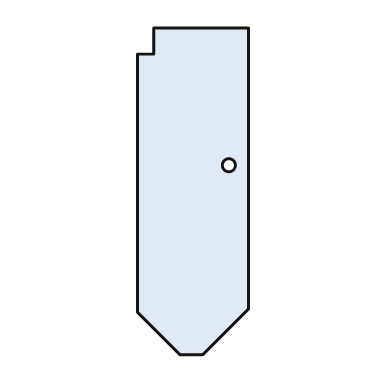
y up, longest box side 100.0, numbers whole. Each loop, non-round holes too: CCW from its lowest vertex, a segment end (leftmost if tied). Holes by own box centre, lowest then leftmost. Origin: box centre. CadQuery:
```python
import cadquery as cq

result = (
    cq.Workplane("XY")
    .moveTo(-4.0, -50.0)
    .lineTo(3.0, -50.0)
    .lineTo(17.0, -36.0)
    .lineTo(17.0, 50.0)
    .lineTo(-12.0, 50.0)
    .lineTo(-12.0, 42.0)
    .lineTo(-17.0, 42.0)
    .lineTo(-17.0, -37.0)
    .close()
    .moveTo(11.0, 8.0)
    .circle(2.0)
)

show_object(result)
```